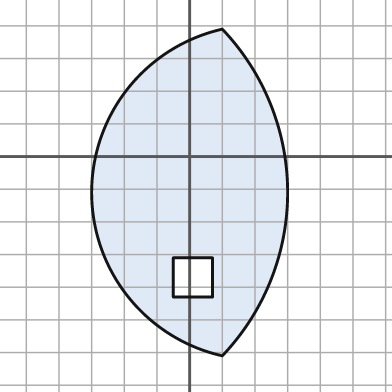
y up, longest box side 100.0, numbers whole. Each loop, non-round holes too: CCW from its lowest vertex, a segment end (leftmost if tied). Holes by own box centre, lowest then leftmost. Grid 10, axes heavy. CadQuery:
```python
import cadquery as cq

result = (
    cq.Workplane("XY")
    .moveTo(10.0, -61.0)
    .threePointArc((30.0, -11.0), (10.0, 39.0))
    .threePointArc((-30.0, -11.0), (10.0, -61.0))
    .close()
    .moveTo(-5.0, -43.0)
    .lineTo(7.0, -43.0)
    .lineTo(7.0, -31.0)
    .lineTo(-5.0, -31.0)
    .close()
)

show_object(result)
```